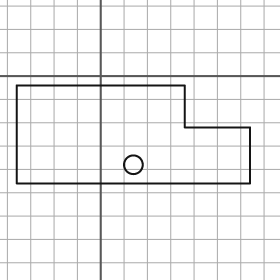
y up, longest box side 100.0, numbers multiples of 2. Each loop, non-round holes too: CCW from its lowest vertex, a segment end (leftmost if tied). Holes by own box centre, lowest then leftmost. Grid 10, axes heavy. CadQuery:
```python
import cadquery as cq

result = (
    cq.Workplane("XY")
    .moveTo(-36.0, -46.0)
    .lineTo(64.0, -46.0)
    .lineTo(64.0, -22.0)
    .lineTo(36.0, -22.0)
    .lineTo(36.0, -4.0)
    .lineTo(-36.0, -4.0)
    .close()
    .moveTo(14.0, -38.0)
    .circle(4.0)
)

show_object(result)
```